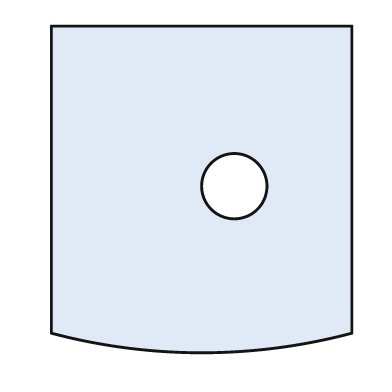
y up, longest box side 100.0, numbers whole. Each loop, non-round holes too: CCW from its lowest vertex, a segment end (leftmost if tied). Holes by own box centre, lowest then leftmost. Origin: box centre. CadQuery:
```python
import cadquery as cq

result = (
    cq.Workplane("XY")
    .moveTo(-46.0, -44.0)
    .threePointArc((0.0, -50.0), (46.0, -44.0))
    .lineTo(46.0, 50.0)
    .lineTo(-46.0, 50.0)
    .close()
    .moveTo(10.0, 1.0)
    .circle(10.0)
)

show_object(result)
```